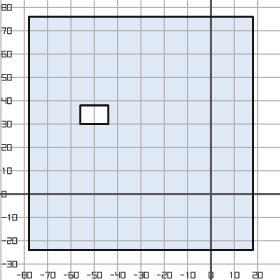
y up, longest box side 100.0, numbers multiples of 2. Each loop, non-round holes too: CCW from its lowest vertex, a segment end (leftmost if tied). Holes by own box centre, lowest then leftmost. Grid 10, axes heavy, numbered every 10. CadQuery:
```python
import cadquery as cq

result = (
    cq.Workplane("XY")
    .moveTo(-78.0, -24.0)
    .lineTo(18.0, -24.0)
    .lineTo(18.0, 76.0)
    .lineTo(-78.0, 76.0)
    .close()
    .moveTo(-56.0, 30.0)
    .lineTo(-44.0, 30.0)
    .lineTo(-44.0, 38.0)
    .lineTo(-56.0, 38.0)
    .close()
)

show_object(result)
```